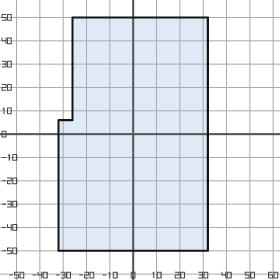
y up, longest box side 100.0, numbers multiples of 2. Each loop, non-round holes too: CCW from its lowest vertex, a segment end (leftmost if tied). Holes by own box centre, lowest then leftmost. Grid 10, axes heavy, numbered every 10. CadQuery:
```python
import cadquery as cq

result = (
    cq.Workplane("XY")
    .moveTo(-32.0, -50.0)
    .lineTo(32.0, -50.0)
    .lineTo(32.0, 50.0)
    .lineTo(-26.0, 50.0)
    .lineTo(-26.0, 6.0)
    .lineTo(-32.0, 6.0)
    .close()
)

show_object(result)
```